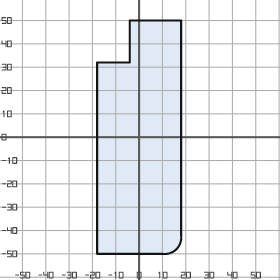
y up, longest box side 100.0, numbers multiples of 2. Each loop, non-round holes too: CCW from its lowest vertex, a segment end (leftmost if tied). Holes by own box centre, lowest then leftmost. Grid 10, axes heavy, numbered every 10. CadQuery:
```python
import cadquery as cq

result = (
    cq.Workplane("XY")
    .moveTo(-18.0, -50.0)
    .lineTo(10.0, -50.0)
    .threePointArc((16.0, -48.0), (18.0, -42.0))
    .lineTo(18.0, 50.0)
    .lineTo(-4.0, 50.0)
    .lineTo(-4.0, 32.0)
    .lineTo(-18.0, 32.0)
    .close()
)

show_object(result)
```